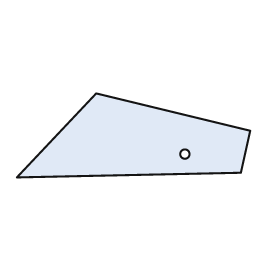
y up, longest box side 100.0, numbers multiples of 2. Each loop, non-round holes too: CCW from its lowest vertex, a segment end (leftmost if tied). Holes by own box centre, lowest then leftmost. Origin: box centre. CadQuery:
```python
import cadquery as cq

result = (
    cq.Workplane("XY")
    .moveTo(-50.0, -18.0)
    .lineTo(46.0, -16.0)
    .lineTo(50.0, 2.0)
    .lineTo(-16.0, 18.0)
    .close()
    .moveTo(22.0, -8.0)
    .circle(2.0)
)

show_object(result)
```